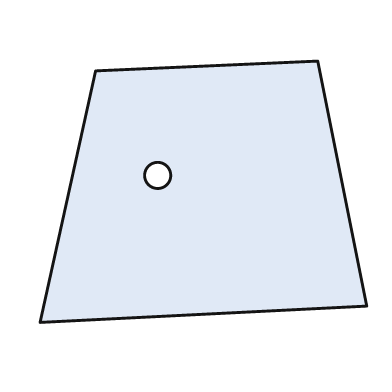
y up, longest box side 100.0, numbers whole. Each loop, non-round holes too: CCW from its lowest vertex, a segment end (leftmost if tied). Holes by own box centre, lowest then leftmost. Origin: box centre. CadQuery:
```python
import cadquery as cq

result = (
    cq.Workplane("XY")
    .moveTo(-50.0, -40.0)
    .lineTo(50.0, -35.0)
    .lineTo(35.0, 40.0)
    .lineTo(-33.0, 37.0)
    .close()
    .moveTo(-14.0, 5.0)
    .circle(4.0)
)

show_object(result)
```